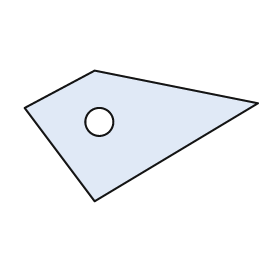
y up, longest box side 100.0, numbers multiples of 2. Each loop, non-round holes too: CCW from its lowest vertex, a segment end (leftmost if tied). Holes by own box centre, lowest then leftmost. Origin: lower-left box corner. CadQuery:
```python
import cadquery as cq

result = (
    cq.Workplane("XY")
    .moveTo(30.0, 0.0)
    .lineTo(100.0, 42.0)
    .lineTo(30.0, 56.0)
    .lineTo(0.0, 40.0)
    .close()
    .moveTo(32.0, 34.0)
    .circle(6.0)
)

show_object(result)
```